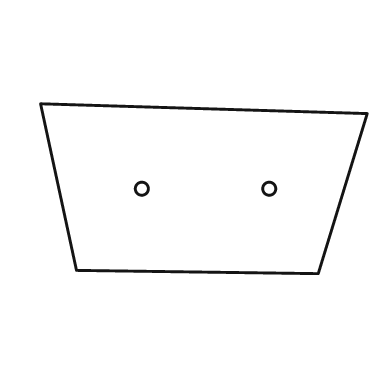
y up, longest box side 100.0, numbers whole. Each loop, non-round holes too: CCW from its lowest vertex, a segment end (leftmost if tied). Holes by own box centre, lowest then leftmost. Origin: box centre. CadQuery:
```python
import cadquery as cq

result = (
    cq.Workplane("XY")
    .moveTo(35.0, -26.0)
    .lineTo(50.0, 23.0)
    .lineTo(-50.0, 26.0)
    .lineTo(-39.0, -25.0)
    .close()
    .moveTo(-19.0, 0.0)
    .circle(2.0)
    .moveTo(20.0, 0.0)
    .circle(2.0)
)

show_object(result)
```